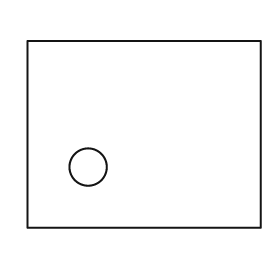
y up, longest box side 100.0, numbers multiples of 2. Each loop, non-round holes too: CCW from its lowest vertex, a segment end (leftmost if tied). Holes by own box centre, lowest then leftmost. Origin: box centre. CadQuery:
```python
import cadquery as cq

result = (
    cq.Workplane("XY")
    .moveTo(-50.0, -40.0)
    .lineTo(50.0, -40.0)
    .lineTo(50.0, 40.0)
    .lineTo(-50.0, 40.0)
    .close()
    .moveTo(-24.0, -14.0)
    .circle(8.0)
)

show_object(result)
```